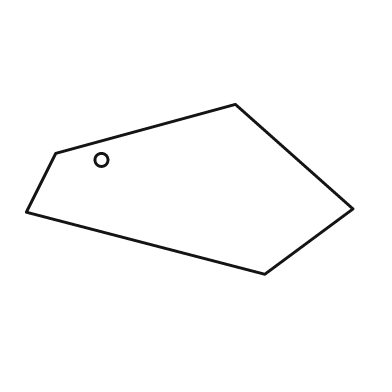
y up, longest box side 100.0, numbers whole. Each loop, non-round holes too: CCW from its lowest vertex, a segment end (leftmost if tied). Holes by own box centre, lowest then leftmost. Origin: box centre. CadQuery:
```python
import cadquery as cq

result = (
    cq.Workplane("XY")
    .moveTo(23.0, -26.0)
    .lineTo(50.0, -6.0)
    .lineTo(14.0, 26.0)
    .lineTo(-41.0, 11.0)
    .lineTo(-50.0, -7.0)
    .close()
    .moveTo(-27.0, 9.0)
    .circle(2.0)
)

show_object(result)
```